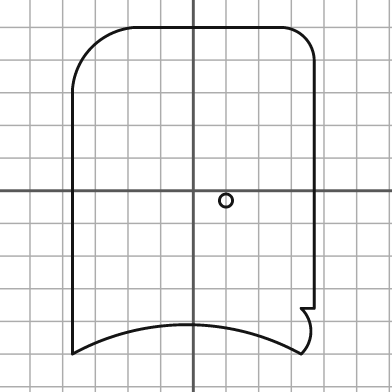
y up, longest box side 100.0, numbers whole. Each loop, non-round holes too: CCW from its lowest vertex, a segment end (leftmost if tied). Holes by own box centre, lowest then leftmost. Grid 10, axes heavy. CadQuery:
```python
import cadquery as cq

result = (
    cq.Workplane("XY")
    .moveTo(-37.0, -50.0)
    .threePointArc((-2.0, -41.0), (33.0, -50.0))
    .threePointArc((36.0, -43.0), (33.0, -36.0))
    .lineTo(37.0, -36.0)
    .lineTo(37.0, 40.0)
    .threePointArc((34.0, 47.0), (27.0, 50.0))
    .lineTo(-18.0, 50.0)
    .threePointArc((-31.0, 44.0), (-37.0, 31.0))
    .close()
    .moveTo(10.0, -3.0)
    .circle(2.0)
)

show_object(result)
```